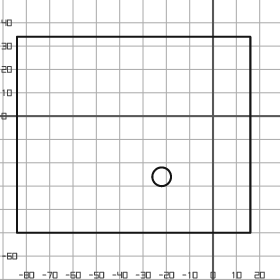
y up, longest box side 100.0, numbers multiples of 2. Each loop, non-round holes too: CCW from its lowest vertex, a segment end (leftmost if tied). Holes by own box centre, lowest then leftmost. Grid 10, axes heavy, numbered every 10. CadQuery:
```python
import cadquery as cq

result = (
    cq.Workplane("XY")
    .moveTo(-84.0, -50.0)
    .lineTo(16.0, -50.0)
    .lineTo(16.0, 34.0)
    .lineTo(-84.0, 34.0)
    .close()
    .moveTo(-22.0, -26.0)
    .circle(4.0)
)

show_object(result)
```